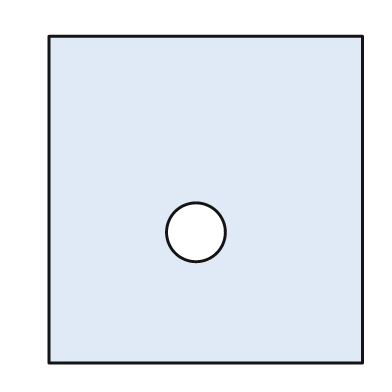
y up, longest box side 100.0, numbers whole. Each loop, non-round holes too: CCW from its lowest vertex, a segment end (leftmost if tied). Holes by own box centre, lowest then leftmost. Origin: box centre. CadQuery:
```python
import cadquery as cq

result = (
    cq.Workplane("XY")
    .moveTo(-48.0, -50.0)
    .lineTo(48.0, -50.0)
    .lineTo(48.0, 50.0)
    .lineTo(-48.0, 50.0)
    .close()
    .moveTo(-3.0, -10.0)
    .circle(9.0)
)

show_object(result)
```